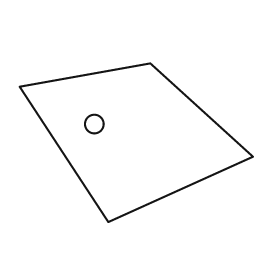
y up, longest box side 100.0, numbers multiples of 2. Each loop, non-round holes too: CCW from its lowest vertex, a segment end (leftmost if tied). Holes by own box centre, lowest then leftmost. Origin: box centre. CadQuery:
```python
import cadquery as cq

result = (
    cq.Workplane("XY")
    .moveTo(-12.0, -34.0)
    .lineTo(50.0, -6.0)
    .lineTo(6.0, 34.0)
    .lineTo(-50.0, 24.0)
    .close()
    .moveTo(-18.0, 8.0)
    .circle(4.0)
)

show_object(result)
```